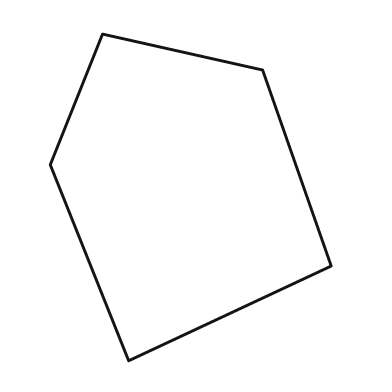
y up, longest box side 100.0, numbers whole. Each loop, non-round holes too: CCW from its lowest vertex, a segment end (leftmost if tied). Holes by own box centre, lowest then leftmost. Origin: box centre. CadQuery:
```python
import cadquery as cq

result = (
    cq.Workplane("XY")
    .moveTo(-19.0, -50.0)
    .lineTo(43.0, -21.0)
    .lineTo(22.0, 39.0)
    .lineTo(-27.0, 50.0)
    .lineTo(-43.0, 10.0)
    .close()
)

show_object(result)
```